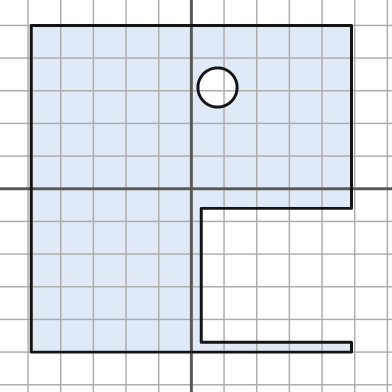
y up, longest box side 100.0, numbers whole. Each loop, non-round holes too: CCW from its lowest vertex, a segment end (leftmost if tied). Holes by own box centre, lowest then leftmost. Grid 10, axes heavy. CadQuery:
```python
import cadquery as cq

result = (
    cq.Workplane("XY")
    .moveTo(-49.0, -50.0)
    .lineTo(49.0, -50.0)
    .lineTo(49.0, -47.0)
    .lineTo(3.0, -47.0)
    .lineTo(3.0, -6.0)
    .lineTo(49.0, -6.0)
    .lineTo(49.0, 50.0)
    .lineTo(-49.0, 50.0)
    .close()
    .moveTo(8.0, 31.0)
    .circle(6.0)
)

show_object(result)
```